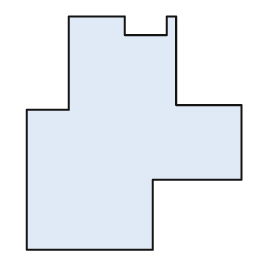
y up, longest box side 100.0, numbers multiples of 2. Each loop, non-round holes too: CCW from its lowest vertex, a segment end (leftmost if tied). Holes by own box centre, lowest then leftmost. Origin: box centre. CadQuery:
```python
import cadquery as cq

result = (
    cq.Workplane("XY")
    .moveTo(-46.0, -50.0)
    .lineTo(8.0, -50.0)
    .lineTo(8.0, -20.0)
    .lineTo(46.0, -20.0)
    .lineTo(46.0, 12.0)
    .lineTo(18.0, 12.0)
    .lineTo(18.0, 50.0)
    .lineTo(14.0, 50.0)
    .lineTo(14.0, 42.0)
    .lineTo(-4.0, 42.0)
    .lineTo(-4.0, 50.0)
    .lineTo(-28.0, 50.0)
    .lineTo(-28.0, 10.0)
    .lineTo(-46.0, 10.0)
    .close()
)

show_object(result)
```